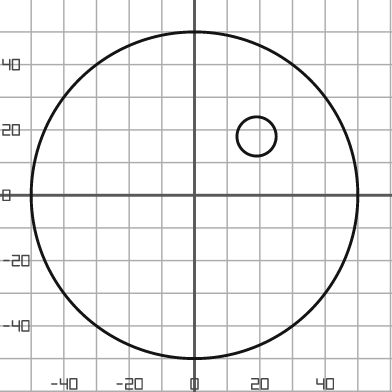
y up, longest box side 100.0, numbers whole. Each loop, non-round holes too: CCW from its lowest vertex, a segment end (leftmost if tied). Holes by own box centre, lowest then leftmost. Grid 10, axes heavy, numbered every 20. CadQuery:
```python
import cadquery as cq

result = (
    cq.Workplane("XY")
    .moveTo(0.0, 0.0)
    .circle(50.0)
    .moveTo(19.0, 18.0)
    .circle(6.0)
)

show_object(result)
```